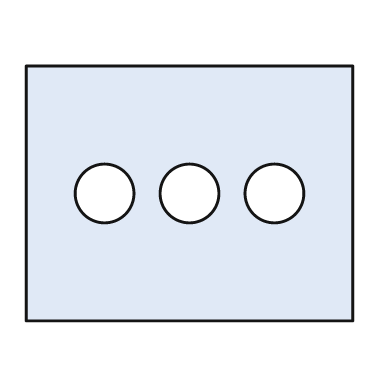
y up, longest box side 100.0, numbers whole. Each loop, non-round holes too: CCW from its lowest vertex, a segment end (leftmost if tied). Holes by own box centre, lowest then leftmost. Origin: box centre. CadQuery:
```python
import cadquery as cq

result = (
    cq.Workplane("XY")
    .moveTo(-50.0, -39.0)
    .lineTo(50.0, -39.0)
    .lineTo(50.0, 39.0)
    .lineTo(-50.0, 39.0)
    .close()
    .moveTo(-26.0, 0.0)
    .circle(9.0)
    .moveTo(0.0, 0.0)
    .circle(9.0)
    .moveTo(26.0, 0.0)
    .circle(9.0)
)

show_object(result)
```